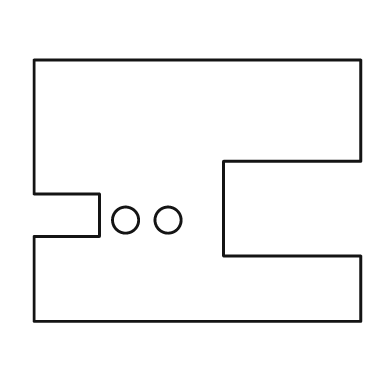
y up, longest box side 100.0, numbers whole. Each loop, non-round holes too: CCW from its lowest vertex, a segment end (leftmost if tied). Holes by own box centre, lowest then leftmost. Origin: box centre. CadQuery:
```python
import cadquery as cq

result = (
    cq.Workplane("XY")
    .moveTo(-50.0, -40.0)
    .lineTo(50.0, -40.0)
    .lineTo(50.0, -20.0)
    .lineTo(8.0, -20.0)
    .lineTo(8.0, 9.0)
    .lineTo(50.0, 9.0)
    .lineTo(50.0, 40.0)
    .lineTo(-50.0, 40.0)
    .lineTo(-50.0, -1.0)
    .lineTo(-30.0, -1.0)
    .lineTo(-30.0, -14.0)
    .lineTo(-50.0, -14.0)
    .close()
    .moveTo(-22.0, -9.0)
    .circle(4.0)
    .moveTo(-9.0, -9.0)
    .circle(4.0)
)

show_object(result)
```